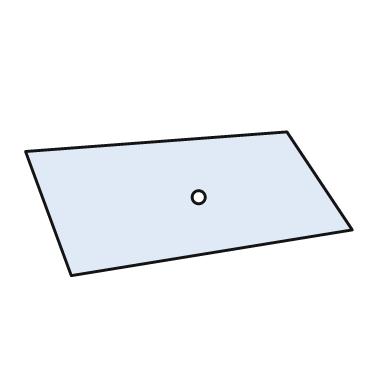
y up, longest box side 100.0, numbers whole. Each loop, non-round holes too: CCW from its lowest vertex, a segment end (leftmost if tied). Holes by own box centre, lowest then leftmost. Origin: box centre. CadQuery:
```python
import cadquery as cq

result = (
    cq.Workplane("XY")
    .moveTo(-36.0, -22.0)
    .lineTo(50.0, -8.0)
    .lineTo(30.0, 22.0)
    .lineTo(-50.0, 16.0)
    .close()
    .moveTo(3.0, 2.0)
    .circle(2.0)
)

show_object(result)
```